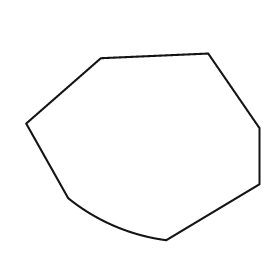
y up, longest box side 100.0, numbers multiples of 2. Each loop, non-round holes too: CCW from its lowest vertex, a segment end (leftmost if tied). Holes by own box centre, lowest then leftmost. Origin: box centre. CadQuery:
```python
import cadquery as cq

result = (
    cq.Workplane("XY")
    .moveTo(10.0, -40.0)
    .lineTo(50.0, -16.0)
    .lineTo(50.0, 8.0)
    .lineTo(28.0, 40.0)
    .lineTo(-18.0, 38.0)
    .lineTo(-50.0, 10.0)
    .lineTo(-32.0, -22.0)
    .threePointArc((-12.0, -34.0), (10.0, -40.0))
    .close()
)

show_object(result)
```